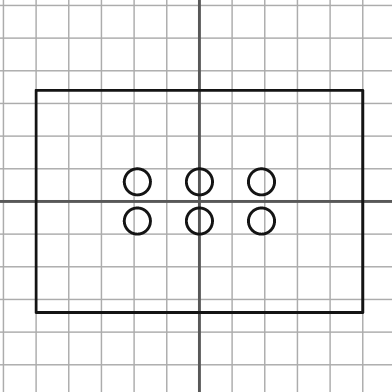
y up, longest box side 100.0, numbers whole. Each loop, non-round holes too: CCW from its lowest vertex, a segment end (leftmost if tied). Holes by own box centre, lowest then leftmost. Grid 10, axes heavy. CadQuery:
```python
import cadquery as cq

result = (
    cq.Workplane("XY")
    .moveTo(-50.0, -34.0)
    .lineTo(50.0, -34.0)
    .lineTo(50.0, 34.0)
    .lineTo(-50.0, 34.0)
    .close()
    .moveTo(-19.0, -6.0)
    .circle(4.0)
    .moveTo(0.0, -6.0)
    .circle(4.0)
    .moveTo(19.0, -6.0)
    .circle(4.0)
    .moveTo(-19.0, 6.0)
    .circle(4.0)
    .moveTo(0.0, 6.0)
    .circle(4.0)
    .moveTo(19.0, 6.0)
    .circle(4.0)
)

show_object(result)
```